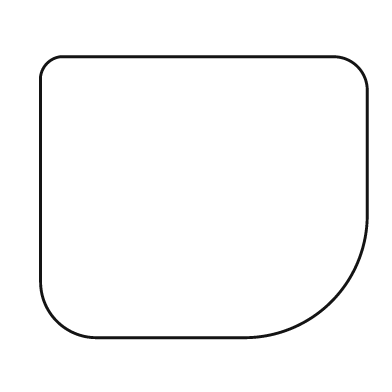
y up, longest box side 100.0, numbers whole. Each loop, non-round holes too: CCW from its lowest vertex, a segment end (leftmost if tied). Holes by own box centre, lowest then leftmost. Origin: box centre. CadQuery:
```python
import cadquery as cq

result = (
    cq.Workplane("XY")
    .moveTo(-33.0, -43.0)
    .lineTo(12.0, -43.0)
    .threePointArc((39.0, -32.0), (50.0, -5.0))
    .lineTo(50.0, 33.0)
    .threePointArc((47.0, 40.0), (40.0, 43.0))
    .lineTo(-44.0, 43.0)
    .threePointArc((-48.0, 41.0), (-50.0, 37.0))
    .lineTo(-50.0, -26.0)
    .threePointArc((-45.0, -38.0), (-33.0, -43.0))
    .close()
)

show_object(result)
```